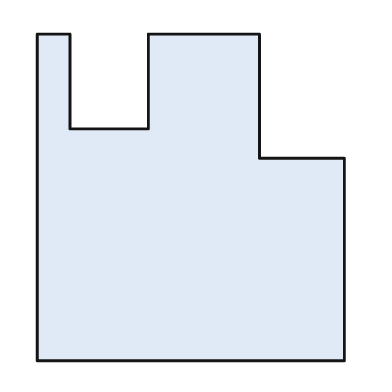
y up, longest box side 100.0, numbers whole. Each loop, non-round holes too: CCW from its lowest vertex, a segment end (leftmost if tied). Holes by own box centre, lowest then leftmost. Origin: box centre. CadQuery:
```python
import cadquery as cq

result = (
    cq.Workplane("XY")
    .moveTo(-47.0, -50.0)
    .lineTo(47.0, -50.0)
    .lineTo(47.0, 12.0)
    .lineTo(21.0, 12.0)
    .lineTo(21.0, 50.0)
    .lineTo(-13.0, 50.0)
    .lineTo(-13.0, 21.0)
    .lineTo(-37.0, 21.0)
    .lineTo(-37.0, 50.0)
    .lineTo(-47.0, 50.0)
    .close()
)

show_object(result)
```